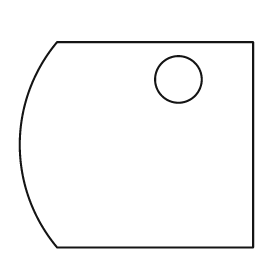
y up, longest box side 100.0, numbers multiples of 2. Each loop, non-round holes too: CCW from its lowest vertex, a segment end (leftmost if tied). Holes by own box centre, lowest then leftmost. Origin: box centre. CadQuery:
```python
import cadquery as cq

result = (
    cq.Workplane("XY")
    .moveTo(-34.0, -44.0)
    .lineTo(50.0, -44.0)
    .lineTo(50.0, 44.0)
    .lineTo(-34.0, 44.0)
    .threePointArc((-50.0, 0.0), (-34.0, -44.0))
    .close()
    .moveTo(18.0, 28.0)
    .circle(10.0)
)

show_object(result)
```